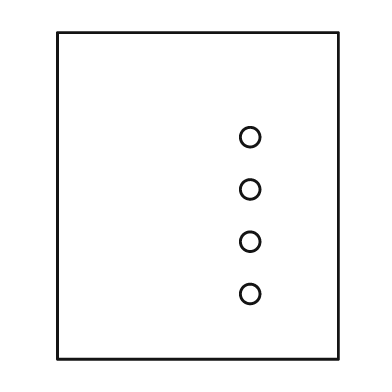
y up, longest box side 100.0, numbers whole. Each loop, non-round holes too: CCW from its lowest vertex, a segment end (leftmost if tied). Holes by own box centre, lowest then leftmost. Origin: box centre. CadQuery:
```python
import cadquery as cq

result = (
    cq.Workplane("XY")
    .moveTo(-43.0, -50.0)
    .lineTo(43.0, -50.0)
    .lineTo(43.0, 50.0)
    .lineTo(-43.0, 50.0)
    .close()
    .moveTo(16.0, -30.0)
    .circle(3.0)
    .moveTo(16.0, -14.0)
    .circle(3.0)
    .moveTo(16.0, 2.0)
    .circle(3.0)
    .moveTo(16.0, 18.0)
    .circle(3.0)
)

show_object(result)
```